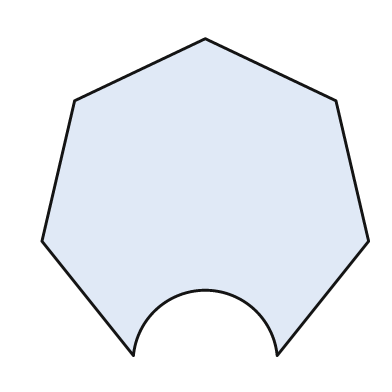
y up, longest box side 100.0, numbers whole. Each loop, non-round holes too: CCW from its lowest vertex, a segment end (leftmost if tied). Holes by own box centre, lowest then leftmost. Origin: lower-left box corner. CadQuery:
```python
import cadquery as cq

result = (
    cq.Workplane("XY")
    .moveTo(28.0, 0.0)
    .threePointArc((50.0, 20.0), (72.0, 0.0))
    .lineTo(100.0, 35.0)
    .lineTo(90.0, 78.0)
    .lineTo(50.0, 97.0)
    .lineTo(10.0, 78.0)
    .lineTo(0.0, 35.0)
    .close()
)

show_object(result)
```